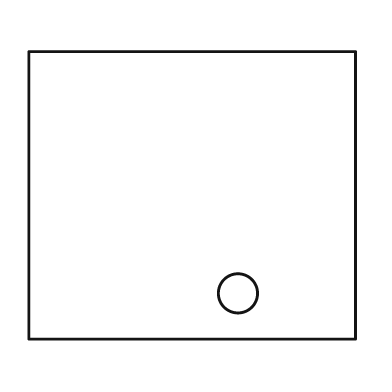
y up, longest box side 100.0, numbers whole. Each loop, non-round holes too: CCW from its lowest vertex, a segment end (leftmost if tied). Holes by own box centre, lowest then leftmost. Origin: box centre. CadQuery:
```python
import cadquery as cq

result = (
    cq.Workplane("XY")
    .moveTo(-50.0, -44.0)
    .lineTo(50.0, -44.0)
    .lineTo(50.0, 44.0)
    .lineTo(-50.0, 44.0)
    .close()
    .moveTo(14.0, -30.0)
    .circle(6.0)
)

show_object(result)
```